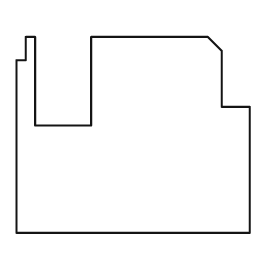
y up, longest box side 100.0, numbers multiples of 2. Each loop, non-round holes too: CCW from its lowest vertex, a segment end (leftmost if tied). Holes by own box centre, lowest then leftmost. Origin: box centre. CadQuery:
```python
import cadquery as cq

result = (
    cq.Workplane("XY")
    .moveTo(-50.0, -42.0)
    .lineTo(50.0, -42.0)
    .lineTo(50.0, 12.0)
    .lineTo(38.0, 12.0)
    .lineTo(38.0, 36.0)
    .lineTo(32.0, 42.0)
    .lineTo(-18.0, 42.0)
    .lineTo(-18.0, 4.0)
    .lineTo(-42.0, 4.0)
    .lineTo(-42.0, 42.0)
    .lineTo(-46.0, 42.0)
    .lineTo(-46.0, 32.0)
    .lineTo(-50.0, 32.0)
    .close()
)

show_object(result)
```